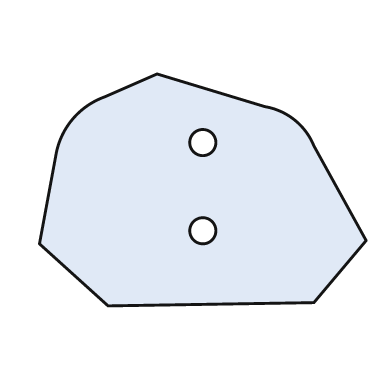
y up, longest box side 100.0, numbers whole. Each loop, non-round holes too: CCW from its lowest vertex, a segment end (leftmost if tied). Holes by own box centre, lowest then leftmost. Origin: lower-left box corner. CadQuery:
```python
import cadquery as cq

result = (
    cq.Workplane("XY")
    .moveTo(21.0, 0.0)
    .lineTo(84.0, 1.0)
    .lineTo(100.0, 20.0)
    .lineTo(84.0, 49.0)
    .threePointArc((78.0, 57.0), (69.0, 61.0))
    .lineTo(36.0, 71.0)
    .lineTo(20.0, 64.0)
    .threePointArc((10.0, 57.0), (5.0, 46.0))
    .lineTo(0.0, 19.0)
    .close()
    .moveTo(50.0, 23.0)
    .circle(4.0)
    .moveTo(50.0, 50.0)
    .circle(4.0)
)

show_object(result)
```